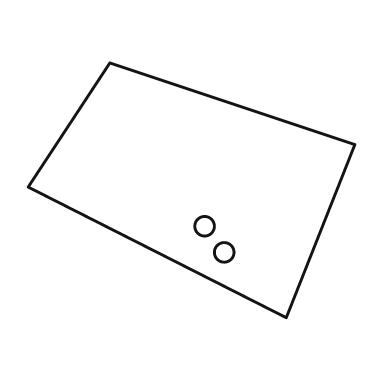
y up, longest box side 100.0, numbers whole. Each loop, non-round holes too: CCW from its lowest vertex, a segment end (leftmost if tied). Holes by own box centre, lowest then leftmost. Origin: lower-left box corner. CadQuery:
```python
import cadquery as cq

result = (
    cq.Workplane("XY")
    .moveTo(79.0, 0.0)
    .lineTo(100.0, 53.0)
    .lineTo(25.0, 78.0)
    .lineTo(0.0, 40.0)
    .close()
    .moveTo(60.0, 20.0)
    .circle(3.0)
    .moveTo(54.0, 28.0)
    .circle(3.0)
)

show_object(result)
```